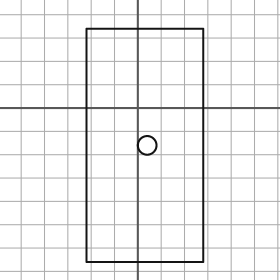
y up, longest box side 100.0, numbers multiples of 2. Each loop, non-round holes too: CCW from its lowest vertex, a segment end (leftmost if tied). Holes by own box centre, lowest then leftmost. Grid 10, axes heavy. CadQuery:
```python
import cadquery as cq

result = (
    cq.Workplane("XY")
    .moveTo(-22.0, -66.0)
    .lineTo(28.0, -66.0)
    .lineTo(28.0, 34.0)
    .lineTo(-22.0, 34.0)
    .close()
    .moveTo(4.0, -16.0)
    .circle(4.0)
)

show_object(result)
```